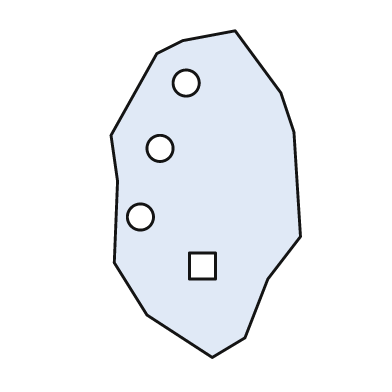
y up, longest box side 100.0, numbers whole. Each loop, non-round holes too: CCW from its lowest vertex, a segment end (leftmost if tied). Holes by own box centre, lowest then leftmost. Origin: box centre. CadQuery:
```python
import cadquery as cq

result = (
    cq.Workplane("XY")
    .moveTo(2.0, -50.0)
    .lineTo(12.0, -44.0)
    .lineTo(19.0, -26.0)
    .lineTo(29.0, -13.0)
    .lineTo(27.0, 19.0)
    .lineTo(23.0, 31.0)
    .lineTo(9.0, 50.0)
    .lineTo(-7.0, 47.0)
    .lineTo(-15.0, 43.0)
    .lineTo(-29.0, 18.0)
    .lineTo(-27.0, 4.0)
    .lineTo(-28.0, -21.0)
    .lineTo(-18.0, -37.0)
    .close()
    .moveTo(-5.0, -26.0)
    .lineTo(3.0, -26.0)
    .lineTo(3.0, -18.0)
    .lineTo(-5.0, -18.0)
    .close()
    .moveTo(-20.0, -7.0)
    .circle(4.0)
    .moveTo(-14.0, 14.0)
    .circle(4.0)
    .moveTo(-6.0, 34.0)
    .circle(4.0)
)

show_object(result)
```